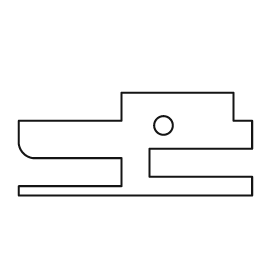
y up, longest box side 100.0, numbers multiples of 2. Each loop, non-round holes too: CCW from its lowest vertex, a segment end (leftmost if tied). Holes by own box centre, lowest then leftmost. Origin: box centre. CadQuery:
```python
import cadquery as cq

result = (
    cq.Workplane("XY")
    .moveTo(-50.0, -22.0)
    .lineTo(50.0, -22.0)
    .lineTo(50.0, -14.0)
    .lineTo(6.0, -14.0)
    .lineTo(6.0, -2.0)
    .lineTo(50.0, -2.0)
    .lineTo(50.0, 10.0)
    .lineTo(42.0, 10.0)
    .lineTo(42.0, 22.0)
    .lineTo(-6.0, 22.0)
    .lineTo(-6.0, 10.0)
    .lineTo(-50.0, 10.0)
    .lineTo(-50.0, 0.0)
    .threePointArc((-48.0, -4.0), (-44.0, -6.0))
    .lineTo(-6.0, -6.0)
    .lineTo(-6.0, -18.0)
    .lineTo(-50.0, -18.0)
    .close()
    .moveTo(12.0, 8.0)
    .circle(4.0)
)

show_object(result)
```